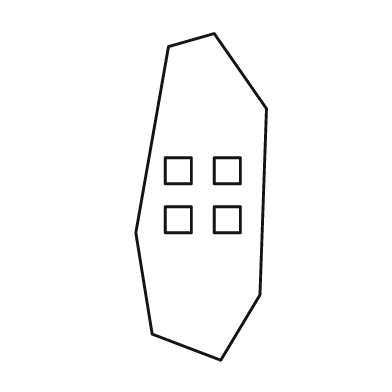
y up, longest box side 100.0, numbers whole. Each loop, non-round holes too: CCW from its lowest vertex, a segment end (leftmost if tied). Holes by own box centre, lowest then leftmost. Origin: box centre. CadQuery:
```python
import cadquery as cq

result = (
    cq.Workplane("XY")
    .moveTo(6.0, -50.0)
    .lineTo(18.0, -30.0)
    .lineTo(20.0, 27.0)
    .lineTo(4.0, 50.0)
    .lineTo(-10.0, 46.0)
    .lineTo(-20.0, -11.0)
    .lineTo(-15.0, -42.0)
    .close()
    .moveTo(-11.0, -11.0)
    .lineTo(-3.0, -11.0)
    .lineTo(-3.0, -3.0)
    .lineTo(-11.0, -3.0)
    .close()
    .moveTo(4.0, -11.0)
    .lineTo(12.0, -11.0)
    .lineTo(12.0, -3.0)
    .lineTo(4.0, -3.0)
    .close()
    .moveTo(-11.0, 4.0)
    .lineTo(-3.0, 4.0)
    .lineTo(-3.0, 12.0)
    .lineTo(-11.0, 12.0)
    .close()
    .moveTo(4.0, 4.0)
    .lineTo(12.0, 4.0)
    .lineTo(12.0, 12.0)
    .lineTo(4.0, 12.0)
    .close()
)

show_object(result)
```